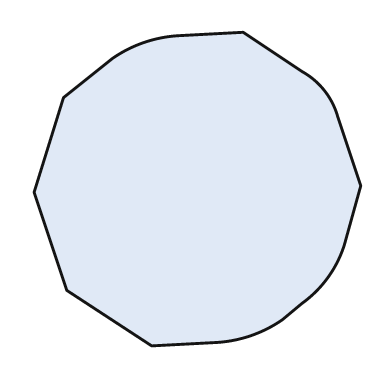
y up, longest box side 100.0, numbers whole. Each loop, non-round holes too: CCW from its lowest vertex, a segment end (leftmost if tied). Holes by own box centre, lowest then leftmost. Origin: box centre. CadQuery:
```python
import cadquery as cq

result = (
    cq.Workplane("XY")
    .moveTo(-14.0, -48.0)
    .lineTo(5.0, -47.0)
    .threePointArc((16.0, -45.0), (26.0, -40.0))
    .lineTo(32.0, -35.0)
    .threePointArc((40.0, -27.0), (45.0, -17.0))
    .lineTo(50.0, 1.0)
    .lineTo(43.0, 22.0)
    .threePointArc((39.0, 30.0), (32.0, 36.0))
    .lineTo(14.0, 48.0)
    .lineTo(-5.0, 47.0)
    .threePointArc((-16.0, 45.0), (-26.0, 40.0))
    .lineTo(-41.0, 28.0)
    .lineTo(-50.0, -1.0)
    .lineTo(-40.0, -31.0)
    .close()
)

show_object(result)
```